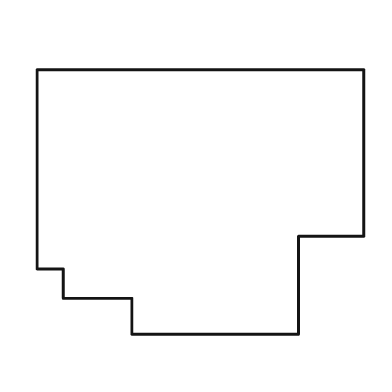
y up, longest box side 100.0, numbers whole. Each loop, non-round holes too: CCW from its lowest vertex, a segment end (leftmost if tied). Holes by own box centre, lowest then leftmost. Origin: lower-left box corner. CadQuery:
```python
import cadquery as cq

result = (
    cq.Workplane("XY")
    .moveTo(29.0, 0.0)
    .lineTo(80.0, 0.0)
    .lineTo(80.0, 30.0)
    .lineTo(100.0, 30.0)
    .lineTo(100.0, 81.0)
    .lineTo(0.0, 81.0)
    .lineTo(0.0, 20.0)
    .lineTo(8.0, 20.0)
    .lineTo(8.0, 11.0)
    .lineTo(29.0, 11.0)
    .close()
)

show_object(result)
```